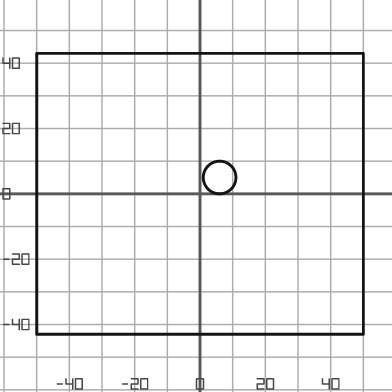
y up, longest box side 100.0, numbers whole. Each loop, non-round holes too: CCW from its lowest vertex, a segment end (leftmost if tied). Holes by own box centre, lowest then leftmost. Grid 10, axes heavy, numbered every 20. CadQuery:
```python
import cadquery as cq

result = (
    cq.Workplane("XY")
    .moveTo(-50.0, -43.0)
    .lineTo(50.0, -43.0)
    .lineTo(50.0, 43.0)
    .lineTo(-50.0, 43.0)
    .close()
    .moveTo(6.0, 5.0)
    .circle(5.0)
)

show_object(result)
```